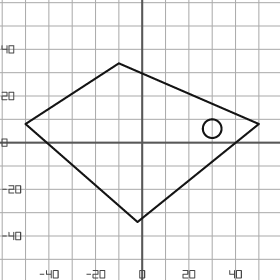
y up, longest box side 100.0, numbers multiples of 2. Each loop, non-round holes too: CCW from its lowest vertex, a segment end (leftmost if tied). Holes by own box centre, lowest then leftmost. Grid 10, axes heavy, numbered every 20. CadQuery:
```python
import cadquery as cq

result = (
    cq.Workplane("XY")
    .moveTo(-2.0, -34.0)
    .lineTo(50.0, 8.0)
    .lineTo(-10.0, 34.0)
    .lineTo(-50.0, 8.0)
    .close()
    .moveTo(30.0, 6.0)
    .circle(4.0)
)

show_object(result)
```